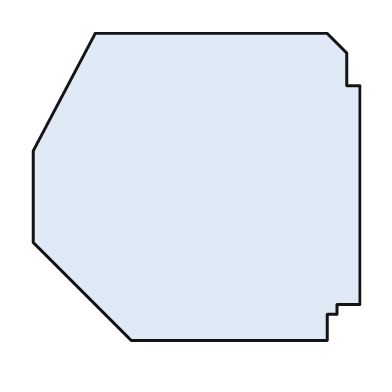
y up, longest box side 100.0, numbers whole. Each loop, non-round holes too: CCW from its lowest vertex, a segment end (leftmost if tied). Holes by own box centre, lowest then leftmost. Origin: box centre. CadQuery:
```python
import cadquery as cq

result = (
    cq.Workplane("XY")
    .moveTo(-20.0, -47.0)
    .lineTo(40.0, -47.0)
    .lineTo(40.0, -39.0)
    .lineTo(43.0, -39.0)
    .lineTo(43.0, -36.0)
    .lineTo(50.0, -36.0)
    .lineTo(50.0, 31.0)
    .lineTo(46.0, 31.0)
    .lineTo(46.0, 41.0)
    .lineTo(40.0, 47.0)
    .lineTo(-31.0, 47.0)
    .lineTo(-50.0, 11.0)
    .lineTo(-50.0, -17.0)
    .close()
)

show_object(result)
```